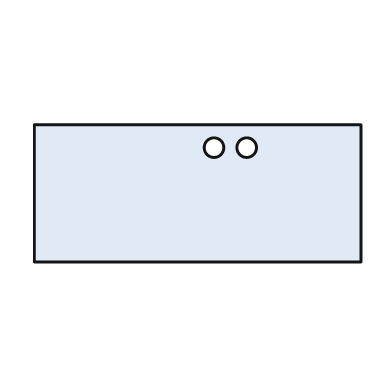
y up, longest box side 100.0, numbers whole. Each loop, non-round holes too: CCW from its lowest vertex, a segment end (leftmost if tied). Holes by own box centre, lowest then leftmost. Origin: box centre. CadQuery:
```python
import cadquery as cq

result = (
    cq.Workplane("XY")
    .moveTo(-50.0, -21.0)
    .lineTo(50.0, -21.0)
    .lineTo(50.0, 21.0)
    .lineTo(-50.0, 21.0)
    .close()
    .moveTo(5.0, 14.0)
    .circle(3.0)
    .moveTo(15.0, 14.0)
    .circle(3.0)
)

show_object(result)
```